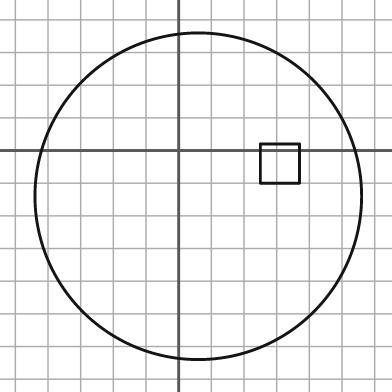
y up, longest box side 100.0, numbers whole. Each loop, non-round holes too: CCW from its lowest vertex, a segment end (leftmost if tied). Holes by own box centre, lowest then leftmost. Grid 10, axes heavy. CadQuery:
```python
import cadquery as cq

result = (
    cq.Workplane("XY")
    .moveTo(6.0, -14.0)
    .circle(50.0)
    .moveTo(25.0, -10.0)
    .lineTo(37.0, -10.0)
    .lineTo(37.0, 2.0)
    .lineTo(25.0, 2.0)
    .close()
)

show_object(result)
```